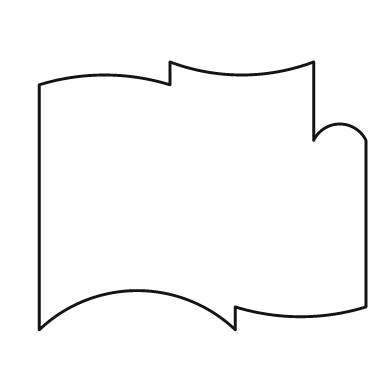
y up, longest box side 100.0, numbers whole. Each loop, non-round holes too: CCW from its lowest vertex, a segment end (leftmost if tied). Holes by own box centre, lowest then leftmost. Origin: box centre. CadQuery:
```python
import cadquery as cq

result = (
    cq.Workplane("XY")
    .moveTo(-50.0, -41.0)
    .threePointArc((-20.0, -29.0), (10.0, -41.0))
    .lineTo(10.0, -34.0)
    .threePointArc((30.0, -37.0), (50.0, -34.0))
    .lineTo(50.0, 17.0)
    .threePointArc((42.0, 22.0), (34.0, 17.0))
    .lineTo(34.0, 41.0)
    .threePointArc((12.0, 37.0), (-10.0, 41.0))
    .lineTo(-10.0, 34.0)
    .threePointArc((-30.0, 37.0), (-50.0, 34.0))
    .close()
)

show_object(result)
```